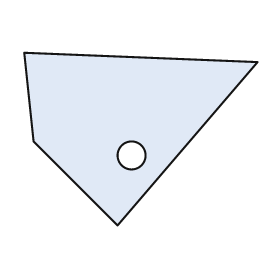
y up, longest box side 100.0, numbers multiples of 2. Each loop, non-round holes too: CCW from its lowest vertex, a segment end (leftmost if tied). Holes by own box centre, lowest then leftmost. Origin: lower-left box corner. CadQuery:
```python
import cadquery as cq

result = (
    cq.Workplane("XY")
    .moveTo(40.0, 0.0)
    .lineTo(100.0, 70.0)
    .lineTo(0.0, 74.0)
    .lineTo(4.0, 36.0)
    .close()
    .moveTo(46.0, 30.0)
    .circle(6.0)
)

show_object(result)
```